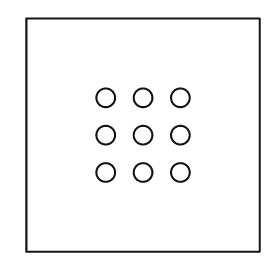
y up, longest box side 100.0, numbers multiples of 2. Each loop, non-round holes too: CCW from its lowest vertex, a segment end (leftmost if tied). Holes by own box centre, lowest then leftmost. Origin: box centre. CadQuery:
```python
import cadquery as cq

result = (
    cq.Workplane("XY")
    .moveTo(-50.0, -50.0)
    .lineTo(50.0, -50.0)
    .lineTo(50.0, 50.0)
    .lineTo(-50.0, 50.0)
    .close()
    .moveTo(-16.0, -16.0)
    .circle(4.0)
    .moveTo(0.0, -16.0)
    .circle(4.0)
    .moveTo(16.0, -16.0)
    .circle(4.0)
    .moveTo(-16.0, 0.0)
    .circle(4.0)
    .moveTo(0.0, 0.0)
    .circle(4.0)
    .moveTo(16.0, 0.0)
    .circle(4.0)
    .moveTo(-16.0, 16.0)
    .circle(4.0)
    .moveTo(0.0, 16.0)
    .circle(4.0)
    .moveTo(16.0, 16.0)
    .circle(4.0)
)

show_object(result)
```